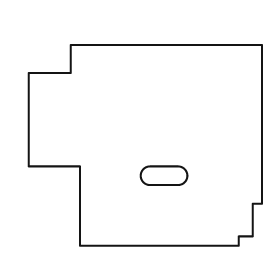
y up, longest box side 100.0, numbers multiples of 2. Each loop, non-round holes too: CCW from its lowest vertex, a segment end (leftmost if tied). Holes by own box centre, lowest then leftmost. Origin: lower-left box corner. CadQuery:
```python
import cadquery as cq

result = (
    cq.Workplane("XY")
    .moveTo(22.0, 0.0)
    .lineTo(90.0, 0.0)
    .lineTo(90.0, 4.0)
    .lineTo(96.0, 4.0)
    .lineTo(96.0, 18.0)
    .lineTo(100.0, 18.0)
    .lineTo(100.0, 86.0)
    .lineTo(18.0, 86.0)
    .lineTo(18.0, 74.0)
    .lineTo(0.0, 74.0)
    .lineTo(0.0, 34.0)
    .lineTo(22.0, 34.0)
    .close()
    .moveTo(52.0, 26.0)
    .lineTo(64.0, 26.0)
    .threePointArc((68.0, 30.0), (64.0, 34.0))
    .lineTo(52.0, 34.0)
    .threePointArc((48.0, 30.0), (52.0, 26.0))
    .close()
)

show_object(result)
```